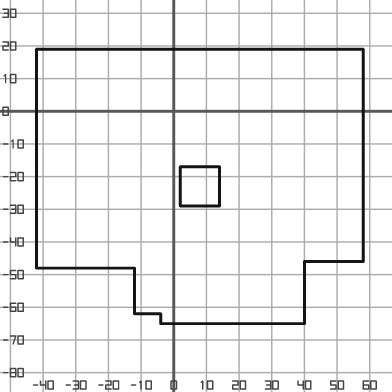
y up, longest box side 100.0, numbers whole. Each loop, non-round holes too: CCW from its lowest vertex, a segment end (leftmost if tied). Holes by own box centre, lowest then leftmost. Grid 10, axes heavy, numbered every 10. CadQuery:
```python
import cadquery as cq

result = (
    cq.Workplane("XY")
    .moveTo(-4.0, -65.0)
    .lineTo(40.0, -65.0)
    .lineTo(40.0, -46.0)
    .lineTo(58.0, -46.0)
    .lineTo(58.0, 19.0)
    .lineTo(-42.0, 19.0)
    .lineTo(-42.0, -48.0)
    .lineTo(-12.0, -48.0)
    .lineTo(-12.0, -62.0)
    .lineTo(-4.0, -62.0)
    .close()
    .moveTo(2.0, -29.0)
    .lineTo(14.0, -29.0)
    .lineTo(14.0, -17.0)
    .lineTo(2.0, -17.0)
    .close()
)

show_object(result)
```